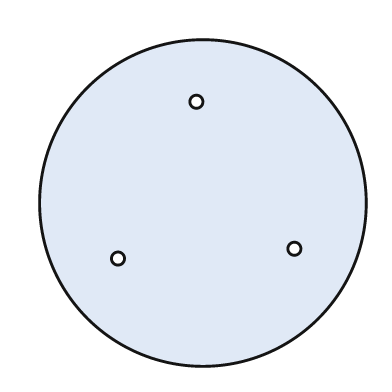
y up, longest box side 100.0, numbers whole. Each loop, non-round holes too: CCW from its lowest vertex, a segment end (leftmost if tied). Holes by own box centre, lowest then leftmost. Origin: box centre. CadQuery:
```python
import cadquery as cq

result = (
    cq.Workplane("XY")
    .moveTo(0.0, 0.0)
    .circle(50.0)
    .moveTo(-26.0, -17.0)
    .circle(2.0)
    .moveTo(28.0, -14.0)
    .circle(2.0)
    .moveTo(-2.0, 31.0)
    .circle(2.0)
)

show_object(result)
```